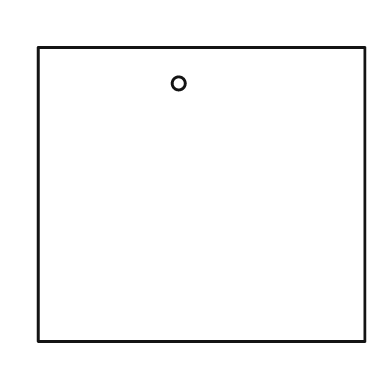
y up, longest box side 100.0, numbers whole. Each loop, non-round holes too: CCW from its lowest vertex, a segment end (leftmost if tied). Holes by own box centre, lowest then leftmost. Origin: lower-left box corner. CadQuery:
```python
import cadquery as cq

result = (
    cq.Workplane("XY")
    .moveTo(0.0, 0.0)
    .lineTo(100.0, 0.0)
    .lineTo(100.0, 90.0)
    .lineTo(0.0, 90.0)
    .close()
    .moveTo(43.0, 79.0)
    .circle(2.0)
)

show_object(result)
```